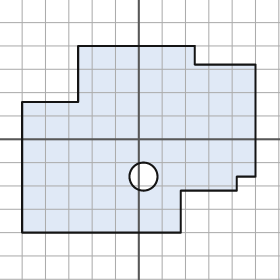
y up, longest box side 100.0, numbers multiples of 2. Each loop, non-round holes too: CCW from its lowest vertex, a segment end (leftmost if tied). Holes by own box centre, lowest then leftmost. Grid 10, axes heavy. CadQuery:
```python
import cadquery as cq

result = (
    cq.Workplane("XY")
    .moveTo(-50.0, -40.0)
    .lineTo(18.0, -40.0)
    .lineTo(18.0, -22.0)
    .lineTo(42.0, -22.0)
    .lineTo(42.0, -16.0)
    .lineTo(50.0, -16.0)
    .lineTo(50.0, 32.0)
    .lineTo(24.0, 32.0)
    .lineTo(24.0, 40.0)
    .lineTo(-26.0, 40.0)
    .lineTo(-26.0, 16.0)
    .lineTo(-50.0, 16.0)
    .close()
    .moveTo(2.0, -16.0)
    .circle(6.0)
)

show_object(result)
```